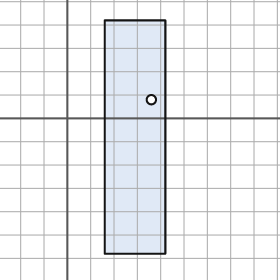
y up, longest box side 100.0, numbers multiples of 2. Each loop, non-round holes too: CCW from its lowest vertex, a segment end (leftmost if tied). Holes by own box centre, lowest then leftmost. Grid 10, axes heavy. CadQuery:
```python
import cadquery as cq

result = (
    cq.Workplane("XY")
    .moveTo(16.0, -58.0)
    .lineTo(42.0, -58.0)
    .lineTo(42.0, 42.0)
    .lineTo(16.0, 42.0)
    .close()
    .moveTo(36.0, 8.0)
    .circle(2.0)
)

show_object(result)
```